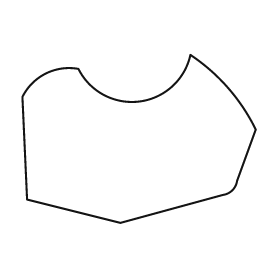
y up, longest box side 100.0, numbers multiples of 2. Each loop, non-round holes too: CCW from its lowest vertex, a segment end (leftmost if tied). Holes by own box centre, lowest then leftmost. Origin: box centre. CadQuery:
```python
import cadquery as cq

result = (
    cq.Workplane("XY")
    .moveTo(-8.0, -36.0)
    .lineTo(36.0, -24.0)
    .threePointArc((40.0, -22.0), (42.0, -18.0))
    .lineTo(50.0, 4.0)
    .threePointArc((38.0, 22.0), (22.0, 36.0))
    .threePointArc((0.0, 16.0), (-26.0, 30.0))
    .threePointArc((-40.0, 28.0), (-50.0, 18.0))
    .lineTo(-48.0, -26.0)
    .close()
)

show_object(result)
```